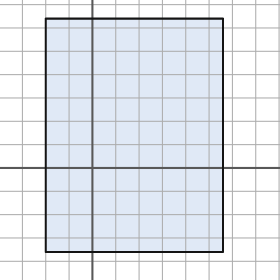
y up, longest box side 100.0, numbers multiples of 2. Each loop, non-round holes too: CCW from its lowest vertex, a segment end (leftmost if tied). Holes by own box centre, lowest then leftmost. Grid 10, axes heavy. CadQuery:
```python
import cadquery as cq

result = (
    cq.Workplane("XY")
    .moveTo(-20.0, -36.0)
    .lineTo(56.0, -36.0)
    .lineTo(56.0, 64.0)
    .lineTo(-20.0, 64.0)
    .close()
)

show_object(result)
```